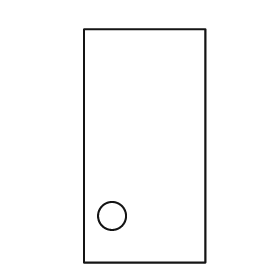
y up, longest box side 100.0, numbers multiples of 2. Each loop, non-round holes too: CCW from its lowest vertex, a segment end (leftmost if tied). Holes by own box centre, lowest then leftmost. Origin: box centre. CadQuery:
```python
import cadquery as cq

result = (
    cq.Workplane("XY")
    .moveTo(-26.0, -50.0)
    .lineTo(26.0, -50.0)
    .lineTo(26.0, 50.0)
    .lineTo(-26.0, 50.0)
    .close()
    .moveTo(-14.0, -30.0)
    .circle(6.0)
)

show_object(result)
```